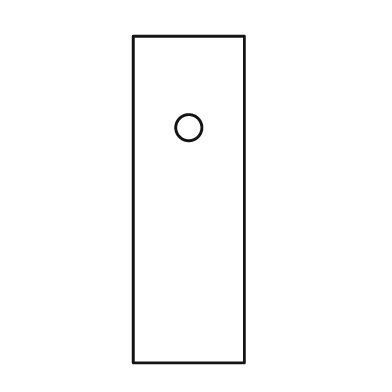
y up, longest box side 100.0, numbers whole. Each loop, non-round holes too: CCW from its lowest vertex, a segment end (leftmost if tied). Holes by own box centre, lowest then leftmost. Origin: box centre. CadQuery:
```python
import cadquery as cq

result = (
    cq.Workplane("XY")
    .moveTo(-17.0, -50.0)
    .lineTo(17.0, -50.0)
    .lineTo(17.0, 50.0)
    .lineTo(-17.0, 50.0)
    .close()
    .moveTo(0.0, 22.0)
    .circle(4.0)
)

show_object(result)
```